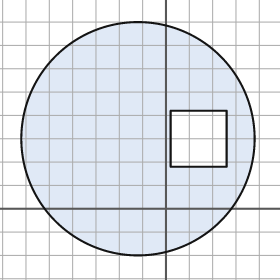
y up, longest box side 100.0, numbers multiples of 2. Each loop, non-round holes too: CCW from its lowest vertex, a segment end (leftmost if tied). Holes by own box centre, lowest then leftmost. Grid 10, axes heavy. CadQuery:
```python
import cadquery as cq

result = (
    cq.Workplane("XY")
    .moveTo(-12.0, 30.0)
    .circle(50.0)
    .moveTo(2.0, 18.0)
    .lineTo(26.0, 18.0)
    .lineTo(26.0, 42.0)
    .lineTo(2.0, 42.0)
    .close()
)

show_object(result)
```